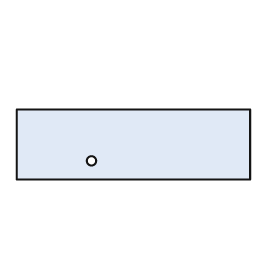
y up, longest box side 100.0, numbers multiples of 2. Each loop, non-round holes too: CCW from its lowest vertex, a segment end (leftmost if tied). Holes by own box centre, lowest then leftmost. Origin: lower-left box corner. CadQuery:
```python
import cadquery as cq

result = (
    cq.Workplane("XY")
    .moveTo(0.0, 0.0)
    .lineTo(100.0, 0.0)
    .lineTo(100.0, 30.0)
    .lineTo(0.0, 30.0)
    .close()
    .moveTo(32.0, 8.0)
    .circle(2.0)
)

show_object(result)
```